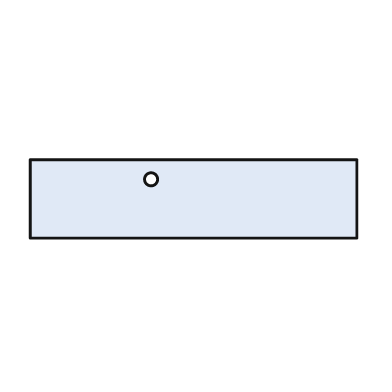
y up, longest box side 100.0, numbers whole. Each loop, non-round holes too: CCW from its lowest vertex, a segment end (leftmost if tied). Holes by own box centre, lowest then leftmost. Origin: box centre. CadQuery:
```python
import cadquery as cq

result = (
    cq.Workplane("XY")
    .moveTo(-50.0, -12.0)
    .lineTo(50.0, -12.0)
    .lineTo(50.0, 12.0)
    .lineTo(-50.0, 12.0)
    .close()
    .moveTo(-13.0, 6.0)
    .circle(2.0)
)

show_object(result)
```